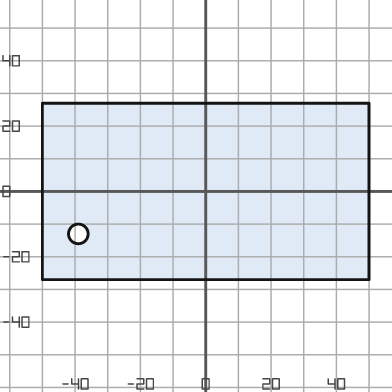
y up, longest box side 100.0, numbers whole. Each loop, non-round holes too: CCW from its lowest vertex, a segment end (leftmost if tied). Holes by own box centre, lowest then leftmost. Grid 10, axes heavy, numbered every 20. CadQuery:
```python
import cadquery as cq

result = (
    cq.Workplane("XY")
    .moveTo(-50.0, -27.0)
    .lineTo(50.0, -27.0)
    .lineTo(50.0, 27.0)
    .lineTo(-50.0, 27.0)
    .close()
    .moveTo(-39.0, -13.0)
    .circle(3.0)
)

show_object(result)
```